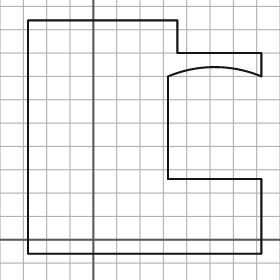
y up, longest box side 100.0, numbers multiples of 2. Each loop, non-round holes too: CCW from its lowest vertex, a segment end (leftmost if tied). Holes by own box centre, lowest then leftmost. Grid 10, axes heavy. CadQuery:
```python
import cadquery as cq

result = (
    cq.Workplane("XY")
    .moveTo(-28.0, -6.0)
    .lineTo(72.0, -6.0)
    .lineTo(72.0, 26.0)
    .lineTo(32.0, 26.0)
    .lineTo(32.0, 70.0)
    .threePointArc((52.0, 74.0), (72.0, 70.0))
    .lineTo(72.0, 80.0)
    .lineTo(36.0, 80.0)
    .lineTo(36.0, 94.0)
    .lineTo(-28.0, 94.0)
    .close()
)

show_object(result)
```